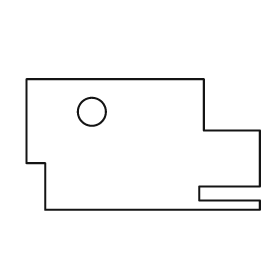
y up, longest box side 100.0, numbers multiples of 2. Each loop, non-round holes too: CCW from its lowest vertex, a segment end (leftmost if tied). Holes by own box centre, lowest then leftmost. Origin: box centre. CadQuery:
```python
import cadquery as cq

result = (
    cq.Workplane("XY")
    .moveTo(-42.0, -28.0)
    .lineTo(50.0, -28.0)
    .lineTo(50.0, -24.0)
    .lineTo(24.0, -24.0)
    .lineTo(24.0, -18.0)
    .lineTo(50.0, -18.0)
    .lineTo(50.0, 6.0)
    .lineTo(26.0, 6.0)
    .lineTo(26.0, 28.0)
    .lineTo(-50.0, 28.0)
    .lineTo(-50.0, -8.0)
    .lineTo(-42.0, -8.0)
    .close()
    .moveTo(-22.0, 14.0)
    .circle(6.0)
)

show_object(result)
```